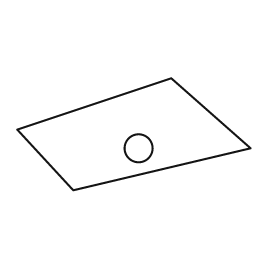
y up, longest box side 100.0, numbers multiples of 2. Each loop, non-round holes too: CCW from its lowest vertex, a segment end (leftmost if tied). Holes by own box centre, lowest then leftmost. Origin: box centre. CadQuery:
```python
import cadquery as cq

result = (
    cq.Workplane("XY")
    .moveTo(-26.0, -24.0)
    .lineTo(50.0, -6.0)
    .lineTo(16.0, 24.0)
    .lineTo(-50.0, 2.0)
    .close()
    .moveTo(2.0, -6.0)
    .circle(6.0)
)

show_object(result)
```